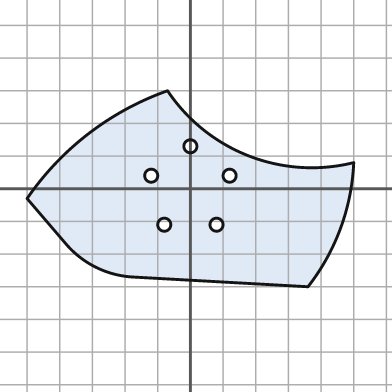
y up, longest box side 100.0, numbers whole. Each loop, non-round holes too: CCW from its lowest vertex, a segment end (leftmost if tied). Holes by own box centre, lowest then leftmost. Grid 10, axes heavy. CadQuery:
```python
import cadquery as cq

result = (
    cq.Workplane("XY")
    .moveTo(36.0, -30.0)
    .threePointArc((46.0, -12.0), (50.0, 8.0))
    .threePointArc((18.0, 10.0), (-7.0, 30.0))
    .threePointArc((-31.0, 17.0), (-50.0, -3.0))
    .lineTo(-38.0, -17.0)
    .threePointArc((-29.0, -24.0), (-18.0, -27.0))
    .close()
    .moveTo(-8.0, -11.0)
    .circle(2.0)
    .moveTo(8.0, -11.0)
    .circle(2.0)
    .moveTo(-12.0, 4.0)
    .circle(2.0)
    .moveTo(12.0, 4.0)
    .circle(2.0)
    .moveTo(0.0, 13.0)
    .circle(2.0)
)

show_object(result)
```